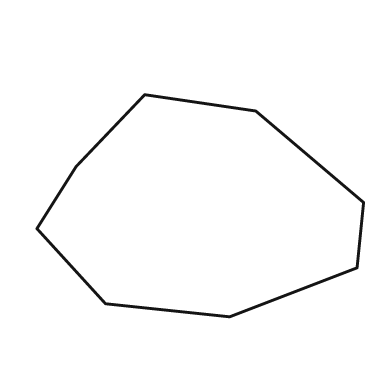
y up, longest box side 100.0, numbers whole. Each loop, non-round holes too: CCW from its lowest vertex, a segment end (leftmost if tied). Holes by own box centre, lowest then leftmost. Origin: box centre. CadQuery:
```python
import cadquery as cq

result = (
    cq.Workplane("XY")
    .moveTo(9.0, -34.0)
    .lineTo(48.0, -19.0)
    .lineTo(50.0, 1.0)
    .lineTo(17.0, 29.0)
    .lineTo(-17.0, 34.0)
    .lineTo(-38.0, 12.0)
    .lineTo(-50.0, -7.0)
    .lineTo(-29.0, -30.0)
    .close()
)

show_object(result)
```